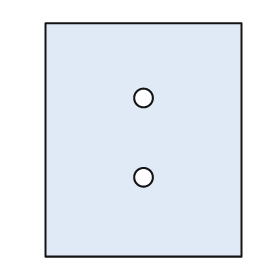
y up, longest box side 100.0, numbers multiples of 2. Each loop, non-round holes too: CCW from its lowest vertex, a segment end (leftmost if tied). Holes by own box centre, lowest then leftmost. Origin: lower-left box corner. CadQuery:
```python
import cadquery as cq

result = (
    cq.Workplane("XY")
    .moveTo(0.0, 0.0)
    .lineTo(84.0, 0.0)
    .lineTo(84.0, 100.0)
    .lineTo(0.0, 100.0)
    .close()
    .moveTo(42.0, 34.0)
    .circle(4.0)
    .moveTo(42.0, 68.0)
    .circle(4.0)
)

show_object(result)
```